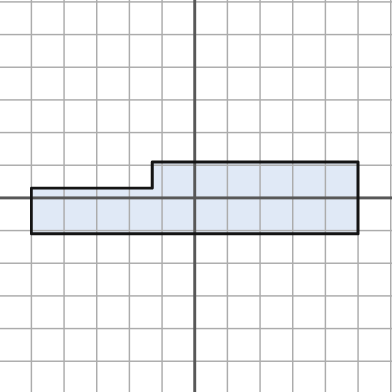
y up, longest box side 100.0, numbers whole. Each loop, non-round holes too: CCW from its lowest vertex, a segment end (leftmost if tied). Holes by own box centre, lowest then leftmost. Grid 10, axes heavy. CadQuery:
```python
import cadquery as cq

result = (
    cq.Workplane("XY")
    .moveTo(-50.0, -11.0)
    .lineTo(50.0, -11.0)
    .lineTo(50.0, 11.0)
    .lineTo(-13.0, 11.0)
    .lineTo(-13.0, 3.0)
    .lineTo(-50.0, 3.0)
    .close()
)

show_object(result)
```